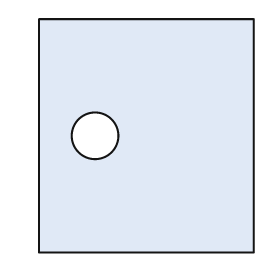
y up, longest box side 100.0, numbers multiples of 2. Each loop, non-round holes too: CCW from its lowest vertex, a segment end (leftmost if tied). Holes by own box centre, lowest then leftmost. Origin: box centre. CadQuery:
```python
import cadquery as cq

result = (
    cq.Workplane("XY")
    .moveTo(-46.0, -50.0)
    .lineTo(46.0, -50.0)
    .lineTo(46.0, 50.0)
    .lineTo(-46.0, 50.0)
    .close()
    .moveTo(-22.0, 0.0)
    .circle(10.0)
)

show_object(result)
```